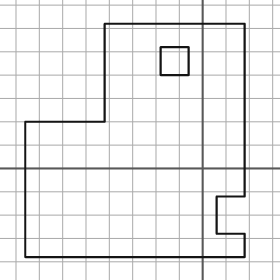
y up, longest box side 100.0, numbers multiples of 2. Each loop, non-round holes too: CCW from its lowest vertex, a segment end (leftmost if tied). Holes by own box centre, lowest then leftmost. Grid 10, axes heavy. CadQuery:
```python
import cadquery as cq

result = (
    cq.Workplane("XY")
    .moveTo(-76.0, -38.0)
    .lineTo(18.0, -38.0)
    .lineTo(18.0, -28.0)
    .lineTo(6.0, -28.0)
    .lineTo(6.0, -12.0)
    .lineTo(18.0, -12.0)
    .lineTo(18.0, 62.0)
    .lineTo(-42.0, 62.0)
    .lineTo(-42.0, 20.0)
    .lineTo(-76.0, 20.0)
    .close()
    .moveTo(-18.0, 40.0)
    .lineTo(-6.0, 40.0)
    .lineTo(-6.0, 52.0)
    .lineTo(-18.0, 52.0)
    .close()
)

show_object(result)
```